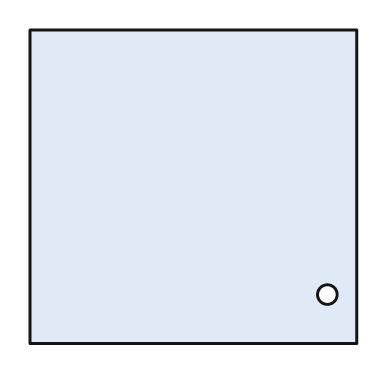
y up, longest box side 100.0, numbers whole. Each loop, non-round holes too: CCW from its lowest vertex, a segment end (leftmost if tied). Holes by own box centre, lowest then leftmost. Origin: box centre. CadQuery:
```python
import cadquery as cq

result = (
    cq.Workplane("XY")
    .moveTo(-50.0, -48.0)
    .lineTo(50.0, -48.0)
    .lineTo(50.0, 48.0)
    .lineTo(-50.0, 48.0)
    .close()
    .moveTo(41.0, -33.0)
    .circle(3.0)
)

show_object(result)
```